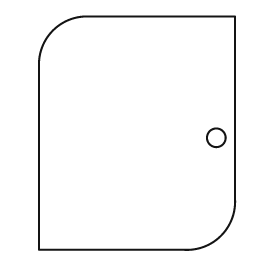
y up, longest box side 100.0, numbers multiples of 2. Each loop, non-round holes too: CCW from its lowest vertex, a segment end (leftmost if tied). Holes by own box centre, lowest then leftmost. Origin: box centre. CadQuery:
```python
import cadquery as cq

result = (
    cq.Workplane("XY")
    .moveTo(-42.0, -50.0)
    .lineTo(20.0, -50.0)
    .threePointArc((36.0, -44.0), (42.0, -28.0))
    .lineTo(42.0, 50.0)
    .lineTo(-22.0, 50.0)
    .threePointArc((-36.0, 44.0), (-42.0, 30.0))
    .close()
    .moveTo(34.0, -2.0)
    .circle(4.0)
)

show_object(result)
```